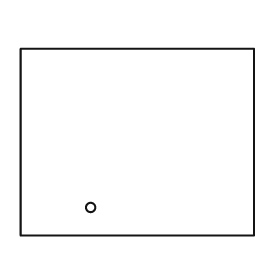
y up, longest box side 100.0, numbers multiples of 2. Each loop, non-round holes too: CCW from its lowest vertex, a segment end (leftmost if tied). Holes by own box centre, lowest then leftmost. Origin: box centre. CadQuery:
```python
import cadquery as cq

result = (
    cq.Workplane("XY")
    .moveTo(-50.0, -40.0)
    .lineTo(50.0, -40.0)
    .lineTo(50.0, 40.0)
    .lineTo(-50.0, 40.0)
    .close()
    .moveTo(-20.0, -28.0)
    .circle(2.0)
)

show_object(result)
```